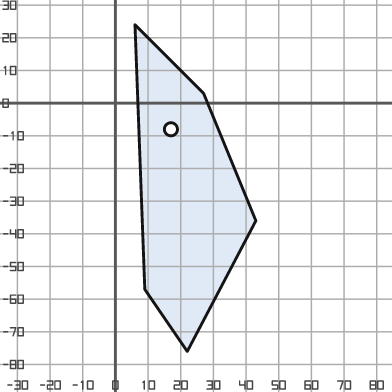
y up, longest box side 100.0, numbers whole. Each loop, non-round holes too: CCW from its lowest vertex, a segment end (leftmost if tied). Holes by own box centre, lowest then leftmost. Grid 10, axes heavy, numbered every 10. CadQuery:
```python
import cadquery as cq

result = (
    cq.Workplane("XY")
    .moveTo(22.0, -76.0)
    .lineTo(43.0, -36.0)
    .lineTo(27.0, 3.0)
    .lineTo(6.0, 24.0)
    .lineTo(9.0, -57.0)
    .close()
    .moveTo(17.0, -8.0)
    .circle(2.0)
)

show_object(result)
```